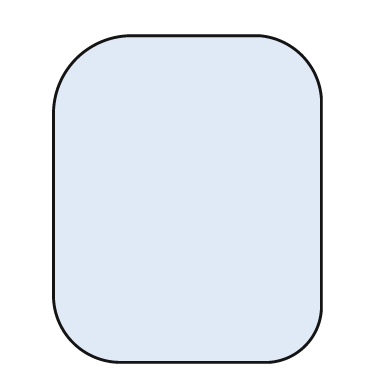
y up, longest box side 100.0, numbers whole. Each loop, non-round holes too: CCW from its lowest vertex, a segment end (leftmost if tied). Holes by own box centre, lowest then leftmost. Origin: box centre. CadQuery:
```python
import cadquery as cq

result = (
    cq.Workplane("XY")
    .moveTo(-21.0, -50.0)
    .lineTo(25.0, -50.0)
    .threePointArc((36.0, -45.0), (41.0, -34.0))
    .lineTo(41.0, 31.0)
    .threePointArc((35.0, 44.0), (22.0, 50.0))
    .lineTo(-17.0, 50.0)
    .threePointArc((-34.0, 43.0), (-41.0, 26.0))
    .lineTo(-41.0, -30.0)
    .threePointArc((-35.0, -44.0), (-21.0, -50.0))
    .close()
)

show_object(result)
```